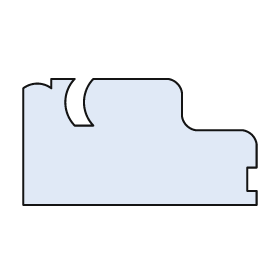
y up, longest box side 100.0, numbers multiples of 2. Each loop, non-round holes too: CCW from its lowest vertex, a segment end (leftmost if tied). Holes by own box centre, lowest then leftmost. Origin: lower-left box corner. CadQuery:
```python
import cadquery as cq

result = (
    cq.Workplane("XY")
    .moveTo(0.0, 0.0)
    .lineTo(100.0, 0.0)
    .lineTo(100.0, 6.0)
    .lineTo(96.0, 6.0)
    .lineTo(96.0, 16.0)
    .lineTo(100.0, 16.0)
    .lineTo(100.0, 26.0)
    .threePointArc((98.0, 30.0), (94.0, 32.0))
    .lineTo(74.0, 32.0)
    .threePointArc((70.0, 34.0), (68.0, 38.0))
    .lineTo(68.0, 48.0)
    .threePointArc((66.0, 52.0), (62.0, 54.0))
    .lineTo(30.0, 54.0)
    .threePointArc((26.0, 44.0), (30.0, 34.0))
    .lineTo(22.0, 34.0)
    .threePointArc((18.0, 44.0), (22.0, 54.0))
    .lineTo(12.0, 54.0)
    .lineTo(12.0, 50.0)
    .threePointArc((6.0, 52.0), (0.0, 50.0))
    .close()
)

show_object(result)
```